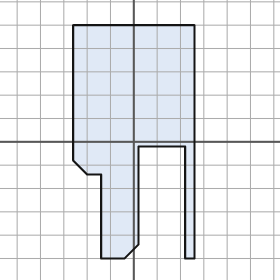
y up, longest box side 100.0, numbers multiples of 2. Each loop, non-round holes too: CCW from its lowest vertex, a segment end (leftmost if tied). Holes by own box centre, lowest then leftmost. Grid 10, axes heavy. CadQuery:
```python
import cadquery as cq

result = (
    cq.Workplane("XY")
    .moveTo(-14.0, -50.0)
    .lineTo(-4.0, -50.0)
    .lineTo(2.0, -44.0)
    .lineTo(2.0, -2.0)
    .lineTo(22.0, -2.0)
    .lineTo(22.0, -50.0)
    .lineTo(26.0, -50.0)
    .lineTo(26.0, 50.0)
    .lineTo(-26.0, 50.0)
    .lineTo(-26.0, -8.0)
    .lineTo(-20.0, -14.0)
    .lineTo(-14.0, -14.0)
    .close()
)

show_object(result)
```